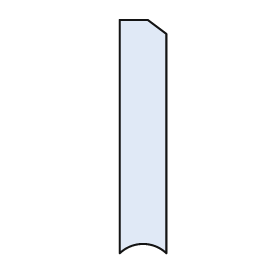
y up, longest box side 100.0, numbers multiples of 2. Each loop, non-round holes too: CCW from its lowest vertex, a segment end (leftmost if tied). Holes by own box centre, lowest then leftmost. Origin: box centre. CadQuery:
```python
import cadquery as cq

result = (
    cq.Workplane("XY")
    .moveTo(-10.0, -50.0)
    .threePointArc((0.0, -46.0), (10.0, -50.0))
    .lineTo(10.0, 44.0)
    .lineTo(2.0, 50.0)
    .lineTo(-10.0, 50.0)
    .close()
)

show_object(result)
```